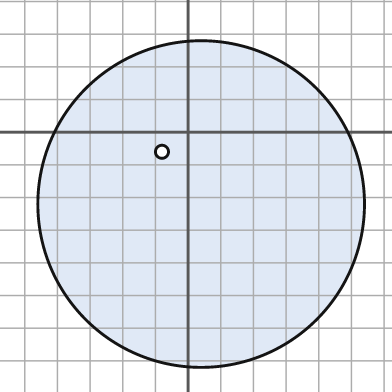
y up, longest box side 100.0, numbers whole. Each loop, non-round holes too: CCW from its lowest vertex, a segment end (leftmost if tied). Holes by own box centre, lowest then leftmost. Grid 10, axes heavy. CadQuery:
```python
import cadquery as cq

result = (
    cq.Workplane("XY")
    .moveTo(4.0, -22.0)
    .circle(50.0)
    .moveTo(-8.0, -6.0)
    .circle(2.0)
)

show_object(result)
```